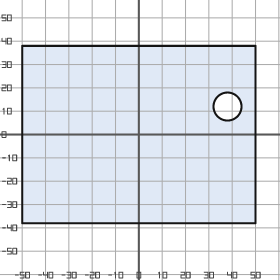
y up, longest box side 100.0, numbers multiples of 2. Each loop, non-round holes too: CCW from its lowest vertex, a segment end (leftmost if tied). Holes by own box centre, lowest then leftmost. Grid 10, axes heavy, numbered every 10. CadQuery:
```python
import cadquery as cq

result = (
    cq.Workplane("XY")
    .moveTo(-50.0, -38.0)
    .lineTo(50.0, -38.0)
    .lineTo(50.0, 38.0)
    .lineTo(-50.0, 38.0)
    .close()
    .moveTo(38.0, 12.0)
    .circle(6.0)
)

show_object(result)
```